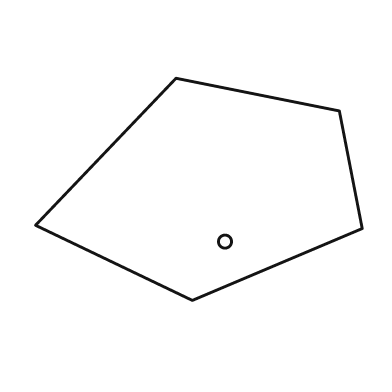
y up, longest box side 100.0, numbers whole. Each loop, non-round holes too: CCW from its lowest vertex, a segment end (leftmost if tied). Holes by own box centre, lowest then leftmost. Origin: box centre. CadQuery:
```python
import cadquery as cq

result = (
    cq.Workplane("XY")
    .moveTo(-2.0, -34.0)
    .lineTo(50.0, -12.0)
    .lineTo(43.0, 24.0)
    .lineTo(-7.0, 34.0)
    .lineTo(-50.0, -11.0)
    .close()
    .moveTo(8.0, -16.0)
    .circle(2.0)
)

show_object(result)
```